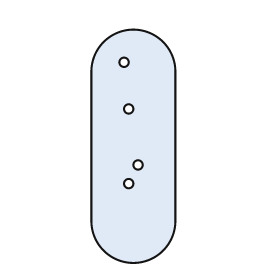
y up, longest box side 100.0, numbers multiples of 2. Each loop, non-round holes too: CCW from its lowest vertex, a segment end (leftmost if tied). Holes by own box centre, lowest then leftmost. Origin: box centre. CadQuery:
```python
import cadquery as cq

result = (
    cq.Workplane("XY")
    .moveTo(-18.0, -32.0)
    .threePointArc((0.0, -50.0), (18.0, -32.0))
    .lineTo(18.0, 32.0)
    .threePointArc((0.0, 50.0), (-18.0, 32.0))
    .close()
    .moveTo(-2.0, -16.0)
    .circle(2.0)
    .moveTo(2.0, -8.0)
    .circle(2.0)
    .moveTo(-2.0, 16.0)
    .circle(2.0)
    .moveTo(-4.0, 36.0)
    .circle(2.0)
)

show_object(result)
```